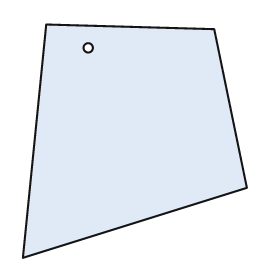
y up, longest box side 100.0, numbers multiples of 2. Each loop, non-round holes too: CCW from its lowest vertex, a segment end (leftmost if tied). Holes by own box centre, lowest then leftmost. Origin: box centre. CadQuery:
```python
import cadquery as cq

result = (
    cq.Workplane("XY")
    .moveTo(-48.0, -50.0)
    .lineTo(48.0, -20.0)
    .lineTo(34.0, 48.0)
    .lineTo(-38.0, 50.0)
    .close()
    .moveTo(-20.0, 40.0)
    .circle(2.0)
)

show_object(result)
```